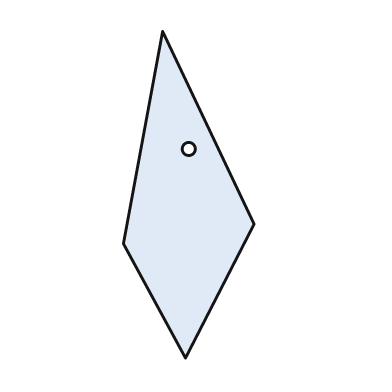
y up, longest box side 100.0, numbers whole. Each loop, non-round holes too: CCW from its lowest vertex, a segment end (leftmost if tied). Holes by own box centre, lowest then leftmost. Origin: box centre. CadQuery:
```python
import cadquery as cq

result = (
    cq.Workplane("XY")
    .moveTo(-1.0, -50.0)
    .lineTo(20.0, -9.0)
    .lineTo(-8.0, 50.0)
    .lineTo(-20.0, -15.0)
    .close()
    .moveTo(0.0, 14.0)
    .circle(2.0)
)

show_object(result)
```